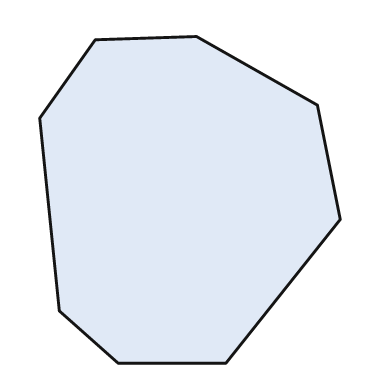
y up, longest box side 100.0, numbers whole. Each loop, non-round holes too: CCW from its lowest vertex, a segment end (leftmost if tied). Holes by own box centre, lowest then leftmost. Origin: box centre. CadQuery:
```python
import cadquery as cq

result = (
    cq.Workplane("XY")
    .moveTo(-22.0, -50.0)
    .lineTo(11.0, -50.0)
    .lineTo(46.0, -6.0)
    .lineTo(39.0, 29.0)
    .lineTo(2.0, 50.0)
    .lineTo(-29.0, 49.0)
    .lineTo(-46.0, 25.0)
    .lineTo(-40.0, -34.0)
    .close()
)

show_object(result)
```